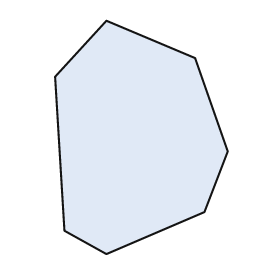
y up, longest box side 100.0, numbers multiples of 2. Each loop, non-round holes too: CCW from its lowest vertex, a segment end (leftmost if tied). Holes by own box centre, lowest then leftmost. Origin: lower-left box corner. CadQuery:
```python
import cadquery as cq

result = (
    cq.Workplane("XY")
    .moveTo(22.0, 0.0)
    .lineTo(64.0, 18.0)
    .lineTo(74.0, 44.0)
    .lineTo(60.0, 84.0)
    .lineTo(22.0, 100.0)
    .lineTo(0.0, 76.0)
    .lineTo(4.0, 10.0)
    .close()
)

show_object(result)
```